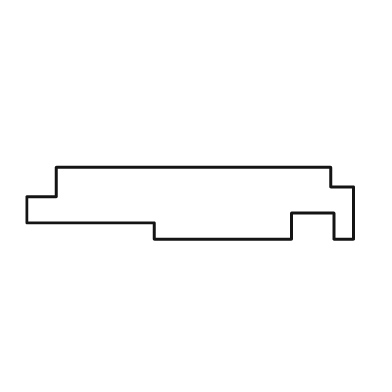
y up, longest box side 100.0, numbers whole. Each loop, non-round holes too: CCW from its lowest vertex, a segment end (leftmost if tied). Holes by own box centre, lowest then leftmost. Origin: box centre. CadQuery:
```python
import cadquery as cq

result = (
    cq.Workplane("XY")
    .moveTo(-11.0, -11.0)
    .lineTo(31.0, -11.0)
    .lineTo(31.0, -3.0)
    .lineTo(44.0, -3.0)
    .lineTo(44.0, -11.0)
    .lineTo(50.0, -11.0)
    .lineTo(50.0, 5.0)
    .lineTo(43.0, 5.0)
    .lineTo(43.0, 11.0)
    .lineTo(-41.0, 11.0)
    .lineTo(-41.0, 2.0)
    .lineTo(-50.0, 2.0)
    .lineTo(-50.0, -6.0)
    .lineTo(-11.0, -6.0)
    .close()
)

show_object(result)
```